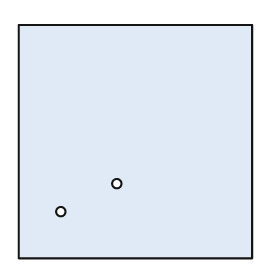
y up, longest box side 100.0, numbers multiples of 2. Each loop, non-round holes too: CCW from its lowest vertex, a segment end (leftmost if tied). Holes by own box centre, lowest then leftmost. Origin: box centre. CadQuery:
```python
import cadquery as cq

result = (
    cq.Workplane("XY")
    .moveTo(-50.0, -50.0)
    .lineTo(50.0, -50.0)
    .lineTo(50.0, 50.0)
    .lineTo(-50.0, 50.0)
    .close()
    .moveTo(-32.0, -30.0)
    .circle(2.0)
    .moveTo(-8.0, -18.0)
    .circle(2.0)
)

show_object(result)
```